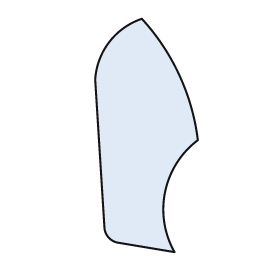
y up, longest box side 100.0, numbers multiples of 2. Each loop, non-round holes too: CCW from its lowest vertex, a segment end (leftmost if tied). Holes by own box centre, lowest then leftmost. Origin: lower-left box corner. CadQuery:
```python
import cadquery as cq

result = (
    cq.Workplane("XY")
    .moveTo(34.0, 0.0)
    .threePointArc((30.0, 26.0), (44.0, 48.0))
    .threePointArc((36.0, 76.0), (20.0, 100.0))
    .threePointArc((6.0, 90.0), (0.0, 74.0))
    .lineTo(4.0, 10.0)
    .threePointArc((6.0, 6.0), (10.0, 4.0))
    .close()
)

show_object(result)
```